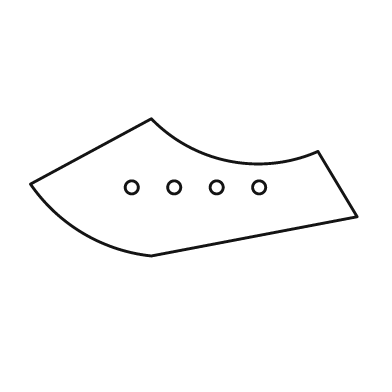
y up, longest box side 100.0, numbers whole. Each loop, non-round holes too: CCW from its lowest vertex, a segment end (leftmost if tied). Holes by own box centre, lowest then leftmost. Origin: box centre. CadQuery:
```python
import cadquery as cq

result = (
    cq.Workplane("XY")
    .moveTo(-13.0, -21.0)
    .lineTo(50.0, -9.0)
    .lineTo(38.0, 11.0)
    .threePointArc((11.0, 8.0), (-13.0, 21.0))
    .lineTo(-50.0, 1.0)
    .threePointArc((-34.0, -14.0), (-13.0, -21.0))
    .close()
    .moveTo(-19.0, 0.0)
    .circle(2.0)
    .moveTo(-6.0, 0.0)
    .circle(2.0)
    .moveTo(7.0, 0.0)
    .circle(2.0)
    .moveTo(20.0, 0.0)
    .circle(2.0)
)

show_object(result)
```